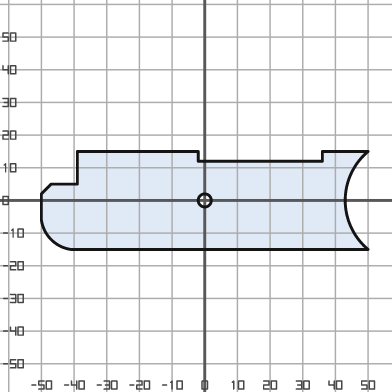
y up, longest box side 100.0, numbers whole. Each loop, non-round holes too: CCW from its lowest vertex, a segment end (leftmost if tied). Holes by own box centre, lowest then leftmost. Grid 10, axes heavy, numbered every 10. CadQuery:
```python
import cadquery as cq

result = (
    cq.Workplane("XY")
    .moveTo(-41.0, -15.0)
    .lineTo(50.0, -15.0)
    .threePointArc((43.0, 0.0), (50.0, 15.0))
    .lineTo(36.0, 15.0)
    .lineTo(36.0, 12.0)
    .lineTo(-2.0, 12.0)
    .lineTo(-2.0, 15.0)
    .lineTo(-39.0, 15.0)
    .lineTo(-39.0, 5.0)
    .lineTo(-47.0, 5.0)
    .lineTo(-50.0, 2.0)
    .lineTo(-50.0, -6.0)
    .threePointArc((-47.0, -12.0), (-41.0, -15.0))
    .close()
    .moveTo(0.0, 0.0)
    .circle(2.0)
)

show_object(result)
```